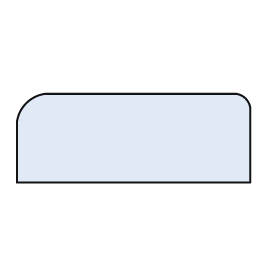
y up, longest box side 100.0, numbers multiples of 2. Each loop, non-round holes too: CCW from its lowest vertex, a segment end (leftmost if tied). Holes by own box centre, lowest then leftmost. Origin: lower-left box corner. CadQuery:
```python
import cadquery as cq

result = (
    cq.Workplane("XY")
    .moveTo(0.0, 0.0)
    .lineTo(100.0, 0.0)
    .lineTo(100.0, 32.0)
    .threePointArc((98.0, 36.0), (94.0, 38.0))
    .lineTo(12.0, 38.0)
    .threePointArc((4.0, 34.0), (0.0, 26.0))
    .close()
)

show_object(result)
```